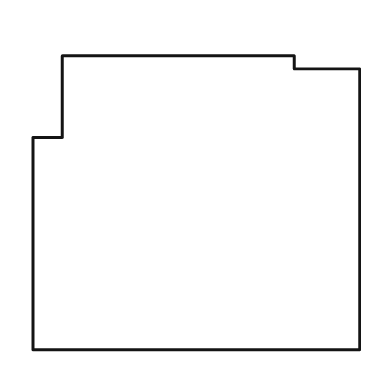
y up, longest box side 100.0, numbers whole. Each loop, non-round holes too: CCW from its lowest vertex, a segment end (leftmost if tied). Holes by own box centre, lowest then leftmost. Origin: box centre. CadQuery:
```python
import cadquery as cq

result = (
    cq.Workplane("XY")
    .moveTo(-50.0, -45.0)
    .lineTo(50.0, -45.0)
    .lineTo(50.0, 41.0)
    .lineTo(30.0, 41.0)
    .lineTo(30.0, 45.0)
    .lineTo(-41.0, 45.0)
    .lineTo(-41.0, 20.0)
    .lineTo(-50.0, 20.0)
    .close()
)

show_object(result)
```